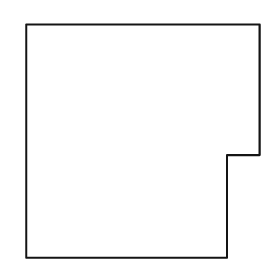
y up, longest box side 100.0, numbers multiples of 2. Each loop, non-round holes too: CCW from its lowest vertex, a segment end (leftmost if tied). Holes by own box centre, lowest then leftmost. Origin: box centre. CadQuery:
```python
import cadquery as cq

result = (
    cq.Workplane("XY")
    .moveTo(-50.0, -50.0)
    .lineTo(36.0, -50.0)
    .lineTo(36.0, -6.0)
    .lineTo(50.0, -6.0)
    .lineTo(50.0, 50.0)
    .lineTo(-50.0, 50.0)
    .close()
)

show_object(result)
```